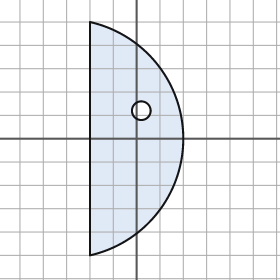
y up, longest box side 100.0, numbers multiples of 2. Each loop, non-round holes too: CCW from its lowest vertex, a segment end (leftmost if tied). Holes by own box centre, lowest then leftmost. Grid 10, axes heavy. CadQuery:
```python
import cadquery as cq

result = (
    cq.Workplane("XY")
    .moveTo(-20.0, -50.0)
    .threePointArc((20.0, 0.0), (-20.0, 50.0))
    .close()
    .moveTo(2.0, 12.0)
    .circle(4.0)
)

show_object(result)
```